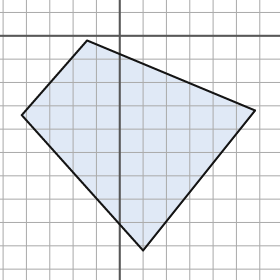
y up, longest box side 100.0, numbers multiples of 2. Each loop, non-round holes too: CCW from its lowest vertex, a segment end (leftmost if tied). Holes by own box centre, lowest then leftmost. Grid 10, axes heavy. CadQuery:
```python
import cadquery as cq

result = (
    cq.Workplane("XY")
    .moveTo(10.0, -92.0)
    .lineTo(58.0, -32.0)
    .lineTo(-14.0, -2.0)
    .lineTo(-42.0, -34.0)
    .close()
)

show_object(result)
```